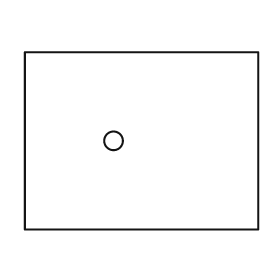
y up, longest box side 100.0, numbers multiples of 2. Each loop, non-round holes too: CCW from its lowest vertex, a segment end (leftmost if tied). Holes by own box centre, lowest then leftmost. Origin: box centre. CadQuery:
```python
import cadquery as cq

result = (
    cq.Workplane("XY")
    .moveTo(-50.0, -38.0)
    .lineTo(50.0, -38.0)
    .lineTo(50.0, 38.0)
    .lineTo(-50.0, 38.0)
    .close()
    .moveTo(-12.0, 0.0)
    .circle(4.0)
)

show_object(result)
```